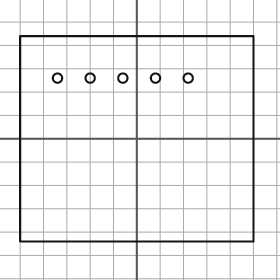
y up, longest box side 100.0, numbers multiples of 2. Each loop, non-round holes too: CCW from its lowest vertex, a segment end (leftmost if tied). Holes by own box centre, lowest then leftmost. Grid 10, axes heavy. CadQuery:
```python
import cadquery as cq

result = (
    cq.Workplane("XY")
    .moveTo(-50.0, -44.0)
    .lineTo(50.0, -44.0)
    .lineTo(50.0, 44.0)
    .lineTo(-50.0, 44.0)
    .close()
    .moveTo(-34.0, 26.0)
    .circle(2.0)
    .moveTo(-20.0, 26.0)
    .circle(2.0)
    .moveTo(-6.0, 26.0)
    .circle(2.0)
    .moveTo(8.0, 26.0)
    .circle(2.0)
    .moveTo(22.0, 26.0)
    .circle(2.0)
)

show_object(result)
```